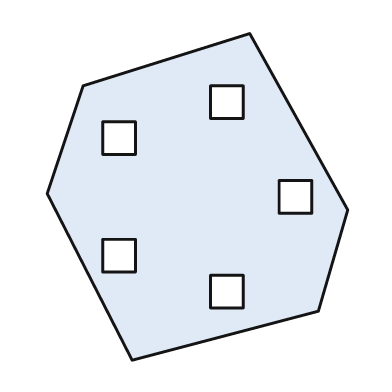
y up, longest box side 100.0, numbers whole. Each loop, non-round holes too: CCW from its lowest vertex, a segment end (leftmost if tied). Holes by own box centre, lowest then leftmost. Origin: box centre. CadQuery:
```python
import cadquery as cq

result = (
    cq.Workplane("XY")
    .moveTo(-20.0, -50.0)
    .lineTo(37.0, -35.0)
    .lineTo(46.0, -4.0)
    .lineTo(16.0, 50.0)
    .lineTo(-35.0, 34.0)
    .lineTo(-46.0, 1.0)
    .close()
    .moveTo(4.0, -34.0)
    .lineTo(14.0, -34.0)
    .lineTo(14.0, -24.0)
    .lineTo(4.0, -24.0)
    .close()
    .moveTo(-29.0, -23.0)
    .lineTo(-19.0, -23.0)
    .lineTo(-19.0, -13.0)
    .lineTo(-29.0, -13.0)
    .close()
    .moveTo(25.0, -5.0)
    .lineTo(35.0, -5.0)
    .lineTo(35.0, 5.0)
    .lineTo(25.0, 5.0)
    .close()
    .moveTo(-29.0, 13.0)
    .lineTo(-19.0, 13.0)
    .lineTo(-19.0, 23.0)
    .lineTo(-29.0, 23.0)
    .close()
    .moveTo(4.0, 24.0)
    .lineTo(14.0, 24.0)
    .lineTo(14.0, 34.0)
    .lineTo(4.0, 34.0)
    .close()
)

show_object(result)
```